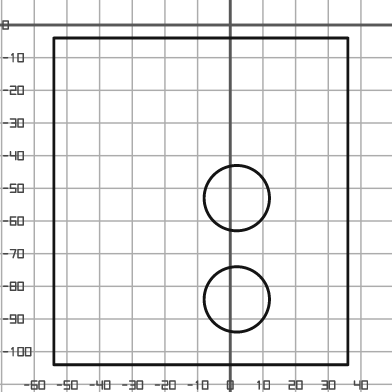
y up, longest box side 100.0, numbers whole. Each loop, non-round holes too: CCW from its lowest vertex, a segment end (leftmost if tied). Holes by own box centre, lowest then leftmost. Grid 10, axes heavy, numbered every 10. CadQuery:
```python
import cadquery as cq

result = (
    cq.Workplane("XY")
    .moveTo(-54.0, -104.0)
    .lineTo(36.0, -104.0)
    .lineTo(36.0, -4.0)
    .lineTo(-54.0, -4.0)
    .close()
    .moveTo(2.0, -84.0)
    .circle(10.0)
    .moveTo(2.0, -53.0)
    .circle(10.0)
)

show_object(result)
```